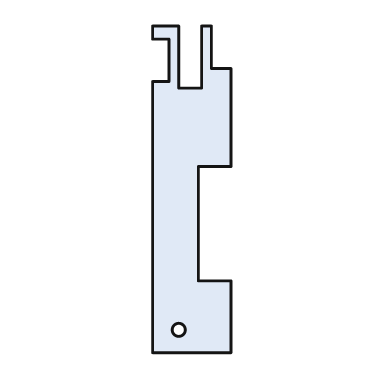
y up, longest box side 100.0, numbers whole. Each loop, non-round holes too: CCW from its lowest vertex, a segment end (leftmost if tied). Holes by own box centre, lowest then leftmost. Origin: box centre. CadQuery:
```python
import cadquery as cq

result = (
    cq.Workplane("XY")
    .moveTo(-12.0, -50.0)
    .lineTo(12.0, -50.0)
    .lineTo(12.0, -28.0)
    .lineTo(2.0, -28.0)
    .lineTo(2.0, 7.0)
    .lineTo(12.0, 7.0)
    .lineTo(12.0, 37.0)
    .lineTo(6.0, 37.0)
    .lineTo(6.0, 50.0)
    .lineTo(3.0, 50.0)
    .lineTo(3.0, 31.0)
    .lineTo(-4.0, 31.0)
    .lineTo(-4.0, 50.0)
    .lineTo(-12.0, 50.0)
    .lineTo(-12.0, 46.0)
    .lineTo(-7.0, 46.0)
    .lineTo(-7.0, 33.0)
    .lineTo(-12.0, 33.0)
    .close()
    .moveTo(-4.0, -43.0)
    .circle(2.0)
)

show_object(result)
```